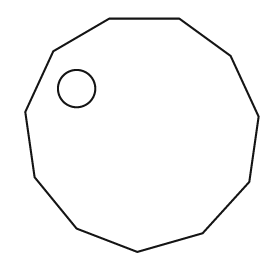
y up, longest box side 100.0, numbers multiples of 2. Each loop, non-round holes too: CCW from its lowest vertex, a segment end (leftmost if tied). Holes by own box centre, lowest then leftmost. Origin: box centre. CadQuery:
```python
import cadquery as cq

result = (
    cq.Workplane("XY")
    .moveTo(-2.0, -50.0)
    .lineTo(26.0, -42.0)
    .lineTo(46.0, -20.0)
    .lineTo(50.0, 8.0)
    .lineTo(38.0, 34.0)
    .lineTo(16.0, 50.0)
    .lineTo(-14.0, 50.0)
    .lineTo(-38.0, 36.0)
    .lineTo(-50.0, 10.0)
    .lineTo(-46.0, -18.0)
    .lineTo(-28.0, -40.0)
    .close()
    .moveTo(-28.0, 20.0)
    .circle(8.0)
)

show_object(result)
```